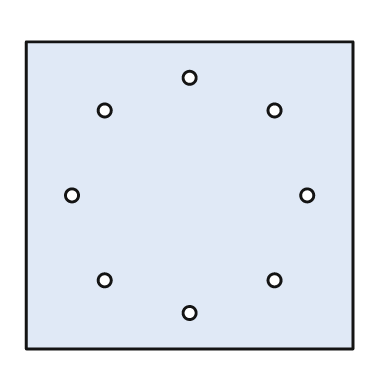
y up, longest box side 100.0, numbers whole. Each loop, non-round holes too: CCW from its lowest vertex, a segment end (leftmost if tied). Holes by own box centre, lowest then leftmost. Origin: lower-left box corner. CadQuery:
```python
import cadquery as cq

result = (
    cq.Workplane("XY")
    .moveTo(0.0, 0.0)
    .lineTo(100.0, 0.0)
    .lineTo(100.0, 94.0)
    .lineTo(0.0, 94.0)
    .close()
    .moveTo(50.0, 11.0)
    .circle(2.0)
    .moveTo(24.0, 21.0)
    .circle(2.0)
    .moveTo(76.0, 21.0)
    .circle(2.0)
    .moveTo(14.0, 47.0)
    .circle(2.0)
    .moveTo(86.0, 47.0)
    .circle(2.0)
    .moveTo(24.0, 73.0)
    .circle(2.0)
    .moveTo(76.0, 73.0)
    .circle(2.0)
    .moveTo(50.0, 83.0)
    .circle(2.0)
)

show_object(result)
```